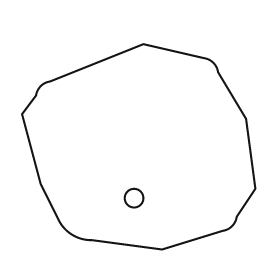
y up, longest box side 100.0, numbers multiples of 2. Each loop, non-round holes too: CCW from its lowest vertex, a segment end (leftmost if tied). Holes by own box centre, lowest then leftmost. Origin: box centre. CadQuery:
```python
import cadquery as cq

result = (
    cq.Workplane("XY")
    .moveTo(10.0, -44.0)
    .lineTo(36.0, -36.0)
    .threePointArc((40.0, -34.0), (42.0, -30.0))
    .lineTo(50.0, -18.0)
    .lineTo(46.0, 12.0)
    .lineTo(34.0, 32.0)
    .threePointArc((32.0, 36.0), (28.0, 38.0))
    .lineTo(2.0, 44.0)
    .lineTo(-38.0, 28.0)
    .threePointArc((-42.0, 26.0), (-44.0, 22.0))
    .lineTo(-50.0, 14.0)
    .lineTo(-42.0, -16.0)
    .lineTo(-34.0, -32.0)
    .threePointArc((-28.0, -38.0), (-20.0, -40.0))
    .close()
    .moveTo(-2.0, -22.0)
    .circle(4.0)
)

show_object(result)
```